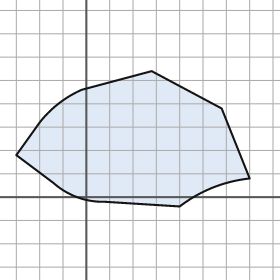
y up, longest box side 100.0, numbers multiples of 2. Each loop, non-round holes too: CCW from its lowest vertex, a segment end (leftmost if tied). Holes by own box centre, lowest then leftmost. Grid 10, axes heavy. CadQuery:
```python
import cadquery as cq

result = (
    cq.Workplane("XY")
    .moveTo(40.0, -4.0)
    .threePointArc((54.0, 4.0), (70.0, 8.0))
    .lineTo(58.0, 38.0)
    .lineTo(28.0, 54.0)
    .lineTo(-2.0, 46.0)
    .threePointArc((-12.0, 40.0), (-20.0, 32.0))
    .lineTo(-30.0, 18.0)
    .lineTo(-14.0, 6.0)
    .threePointArc((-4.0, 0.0), (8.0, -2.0))
    .close()
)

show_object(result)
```